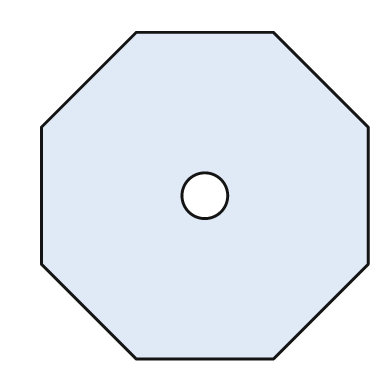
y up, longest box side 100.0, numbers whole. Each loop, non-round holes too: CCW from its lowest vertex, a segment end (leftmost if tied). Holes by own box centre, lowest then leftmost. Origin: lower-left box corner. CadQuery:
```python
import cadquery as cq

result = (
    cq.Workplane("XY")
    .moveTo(29.0, 0.0)
    .lineTo(71.0, 0.0)
    .lineTo(100.0, 29.0)
    .lineTo(100.0, 71.0)
    .lineTo(71.0, 100.0)
    .lineTo(29.0, 100.0)
    .lineTo(0.0, 71.0)
    .lineTo(0.0, 29.0)
    .close()
    .moveTo(50.0, 50.0)
    .circle(7.0)
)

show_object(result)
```